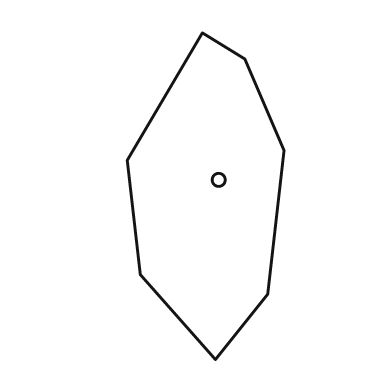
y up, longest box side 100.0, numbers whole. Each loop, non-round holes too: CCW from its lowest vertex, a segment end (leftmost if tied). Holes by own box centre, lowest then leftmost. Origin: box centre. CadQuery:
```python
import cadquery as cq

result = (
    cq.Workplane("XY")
    .moveTo(3.0, -50.0)
    .lineTo(19.0, -30.0)
    .lineTo(24.0, 14.0)
    .lineTo(12.0, 42.0)
    .lineTo(-1.0, 50.0)
    .lineTo(-24.0, 11.0)
    .lineTo(-20.0, -24.0)
    .close()
    .moveTo(4.0, 5.0)
    .circle(2.0)
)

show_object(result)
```